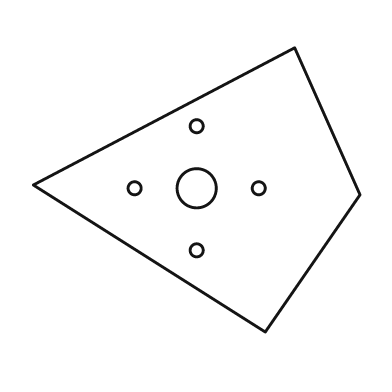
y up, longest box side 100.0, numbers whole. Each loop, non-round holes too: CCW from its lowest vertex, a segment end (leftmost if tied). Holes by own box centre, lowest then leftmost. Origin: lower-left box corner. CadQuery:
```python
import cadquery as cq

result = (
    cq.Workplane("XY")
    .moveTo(71.0, 0.0)
    .lineTo(100.0, 42.0)
    .lineTo(80.0, 87.0)
    .lineTo(0.0, 45.0)
    .close()
    .moveTo(50.0, 25.0)
    .circle(2.0)
    .moveTo(31.0, 44.0)
    .circle(2.0)
    .moveTo(50.0, 44.0)
    .circle(6.0)
    .moveTo(69.0, 44.0)
    .circle(2.0)
    .moveTo(50.0, 63.0)
    .circle(2.0)
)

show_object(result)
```